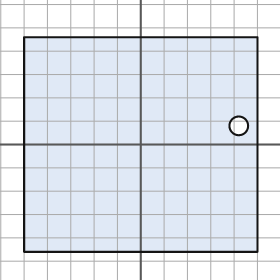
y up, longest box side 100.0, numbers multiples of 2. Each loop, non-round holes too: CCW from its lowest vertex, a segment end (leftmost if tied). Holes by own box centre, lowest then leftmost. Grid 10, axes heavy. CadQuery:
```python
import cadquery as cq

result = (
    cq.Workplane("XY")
    .moveTo(-50.0, -46.0)
    .lineTo(50.0, -46.0)
    .lineTo(50.0, 46.0)
    .lineTo(-50.0, 46.0)
    .close()
    .moveTo(42.0, 8.0)
    .circle(4.0)
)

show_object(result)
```